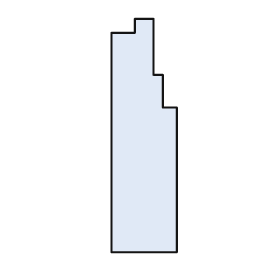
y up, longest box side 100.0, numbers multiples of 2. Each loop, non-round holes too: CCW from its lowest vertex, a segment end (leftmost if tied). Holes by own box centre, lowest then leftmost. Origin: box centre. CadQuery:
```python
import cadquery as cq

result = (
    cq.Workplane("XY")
    .moveTo(-14.0, -50.0)
    .lineTo(14.0, -50.0)
    .lineTo(14.0, 12.0)
    .lineTo(8.0, 12.0)
    .lineTo(8.0, 26.0)
    .lineTo(4.0, 26.0)
    .lineTo(4.0, 50.0)
    .lineTo(-4.0, 50.0)
    .lineTo(-4.0, 44.0)
    .lineTo(-14.0, 44.0)
    .close()
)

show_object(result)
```